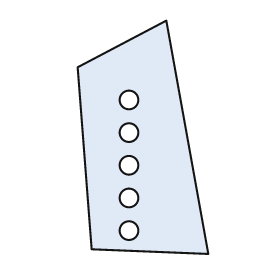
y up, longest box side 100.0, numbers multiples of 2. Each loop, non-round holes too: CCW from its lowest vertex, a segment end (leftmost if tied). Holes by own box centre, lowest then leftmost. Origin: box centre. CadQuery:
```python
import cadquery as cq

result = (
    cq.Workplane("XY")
    .moveTo(28.0, -50.0)
    .lineTo(10.0, 50.0)
    .lineTo(-28.0, 30.0)
    .lineTo(-22.0, -48.0)
    .close()
    .moveTo(-6.0, -40.0)
    .circle(4.0)
    .moveTo(-6.0, -26.0)
    .circle(4.0)
    .moveTo(-6.0, -12.0)
    .circle(4.0)
    .moveTo(-6.0, 2.0)
    .circle(4.0)
    .moveTo(-6.0, 16.0)
    .circle(4.0)
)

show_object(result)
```